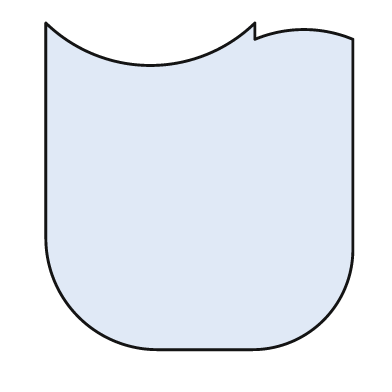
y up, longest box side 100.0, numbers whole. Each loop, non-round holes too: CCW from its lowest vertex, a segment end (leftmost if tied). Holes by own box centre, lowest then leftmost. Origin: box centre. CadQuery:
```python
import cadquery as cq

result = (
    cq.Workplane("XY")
    .moveTo(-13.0, -50.0)
    .lineTo(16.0, -50.0)
    .threePointArc((38.0, -41.0), (47.0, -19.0))
    .lineTo(47.0, 45.0)
    .threePointArc((32.0, 48.0), (17.0, 45.0))
    .lineTo(17.0, 50.0)
    .threePointArc((-15.0, 37.0), (-47.0, 50.0))
    .lineTo(-47.0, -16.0)
    .threePointArc((-37.0, -40.0), (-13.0, -50.0))
    .close()
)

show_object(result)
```